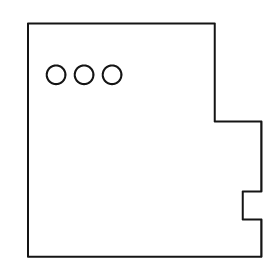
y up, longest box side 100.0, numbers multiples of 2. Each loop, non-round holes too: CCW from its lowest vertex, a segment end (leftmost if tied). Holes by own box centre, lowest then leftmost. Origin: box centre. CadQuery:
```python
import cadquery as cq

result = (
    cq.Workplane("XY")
    .moveTo(-50.0, -50.0)
    .lineTo(50.0, -50.0)
    .lineTo(50.0, -34.0)
    .lineTo(42.0, -34.0)
    .lineTo(42.0, -22.0)
    .lineTo(50.0, -22.0)
    .lineTo(50.0, 8.0)
    .lineTo(30.0, 8.0)
    .lineTo(30.0, 50.0)
    .lineTo(-50.0, 50.0)
    .close()
    .moveTo(-38.0, 28.0)
    .circle(4.0)
    .moveTo(-26.0, 28.0)
    .circle(4.0)
    .moveTo(-14.0, 28.0)
    .circle(4.0)
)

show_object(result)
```